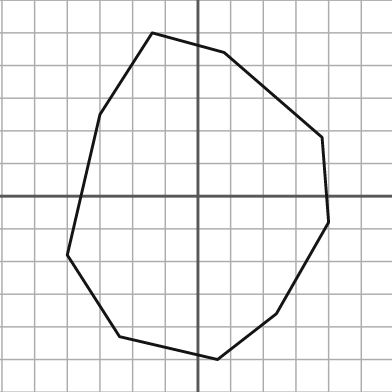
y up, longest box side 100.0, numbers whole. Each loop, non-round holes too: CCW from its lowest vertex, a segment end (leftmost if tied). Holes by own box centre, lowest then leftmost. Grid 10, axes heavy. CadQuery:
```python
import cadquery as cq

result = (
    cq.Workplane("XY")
    .moveTo(6.0, -50.0)
    .lineTo(24.0, -36.0)
    .lineTo(40.0, -8.0)
    .lineTo(38.0, 18.0)
    .lineTo(8.0, 44.0)
    .lineTo(-14.0, 50.0)
    .lineTo(-30.0, 25.0)
    .lineTo(-40.0, -18.0)
    .lineTo(-24.0, -43.0)
    .close()
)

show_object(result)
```